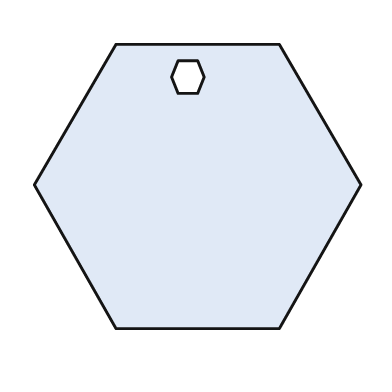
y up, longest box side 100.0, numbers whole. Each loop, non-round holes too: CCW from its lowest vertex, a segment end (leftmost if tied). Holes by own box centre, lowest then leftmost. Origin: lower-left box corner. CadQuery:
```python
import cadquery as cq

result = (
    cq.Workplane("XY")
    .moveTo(25.0, 0.0)
    .lineTo(75.0, 0.0)
    .lineTo(100.0, 44.0)
    .lineTo(75.0, 87.0)
    .lineTo(25.0, 87.0)
    .lineTo(0.0, 44.0)
    .close()
    .moveTo(44.0, 72.0)
    .lineTo(50.0, 72.0)
    .lineTo(52.0, 77.0)
    .lineTo(50.0, 82.0)
    .lineTo(44.0, 82.0)
    .lineTo(42.0, 77.0)
    .close()
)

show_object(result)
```